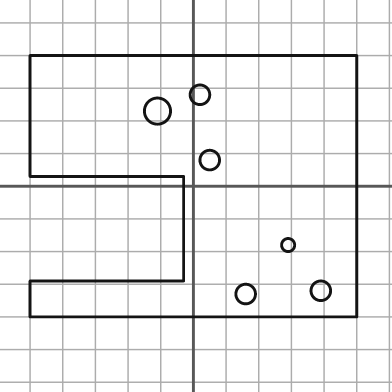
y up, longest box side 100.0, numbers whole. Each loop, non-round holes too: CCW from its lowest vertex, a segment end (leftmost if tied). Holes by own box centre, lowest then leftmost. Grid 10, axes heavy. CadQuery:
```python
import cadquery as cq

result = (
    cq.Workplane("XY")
    .moveTo(-50.0, -40.0)
    .lineTo(50.0, -40.0)
    .lineTo(50.0, 40.0)
    .lineTo(-50.0, 40.0)
    .lineTo(-50.0, 3.0)
    .lineTo(-3.0, 3.0)
    .lineTo(-3.0, -29.0)
    .lineTo(-50.0, -29.0)
    .close()
    .moveTo(16.0, -33.0)
    .circle(3.0)
    .moveTo(39.0, -32.0)
    .circle(3.0)
    .moveTo(29.0, -18.0)
    .circle(2.0)
    .moveTo(5.0, 8.0)
    .circle(3.0)
    .moveTo(-11.0, 23.0)
    .circle(4.0)
    .moveTo(2.0, 28.0)
    .circle(3.0)
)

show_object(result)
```